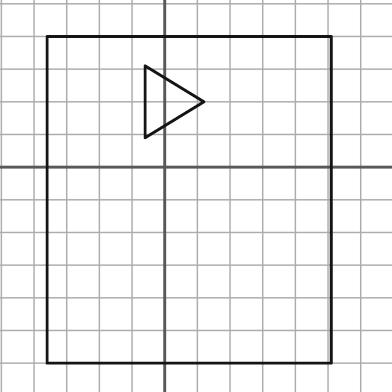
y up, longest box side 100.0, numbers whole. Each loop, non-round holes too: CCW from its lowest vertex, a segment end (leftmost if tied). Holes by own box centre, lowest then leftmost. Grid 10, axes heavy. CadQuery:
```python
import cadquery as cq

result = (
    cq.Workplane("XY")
    .moveTo(-36.0, -60.0)
    .lineTo(51.0, -60.0)
    .lineTo(51.0, 40.0)
    .lineTo(-36.0, 40.0)
    .close()
    .moveTo(-6.0, 9.0)
    .lineTo(12.0, 20.0)
    .lineTo(-6.0, 31.0)
    .close()
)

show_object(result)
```